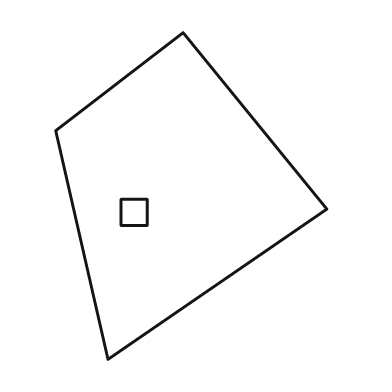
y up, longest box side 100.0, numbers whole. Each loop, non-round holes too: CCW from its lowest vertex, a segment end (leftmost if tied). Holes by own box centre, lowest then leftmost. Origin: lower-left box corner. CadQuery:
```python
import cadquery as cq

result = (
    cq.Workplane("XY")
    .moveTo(16.0, 0.0)
    .lineTo(83.0, 46.0)
    .lineTo(39.0, 100.0)
    .lineTo(0.0, 70.0)
    .close()
    .moveTo(20.0, 41.0)
    .lineTo(28.0, 41.0)
    .lineTo(28.0, 49.0)
    .lineTo(20.0, 49.0)
    .close()
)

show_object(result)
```